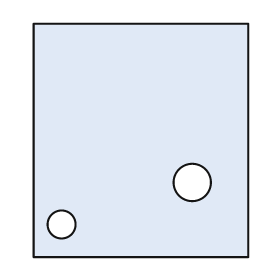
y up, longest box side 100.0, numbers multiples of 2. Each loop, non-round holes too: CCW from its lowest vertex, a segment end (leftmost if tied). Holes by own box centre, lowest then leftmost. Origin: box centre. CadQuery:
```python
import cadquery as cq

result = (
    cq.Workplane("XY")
    .moveTo(-46.0, -50.0)
    .lineTo(46.0, -50.0)
    .lineTo(46.0, 50.0)
    .lineTo(-46.0, 50.0)
    .close()
    .moveTo(-34.0, -36.0)
    .circle(6.0)
    .moveTo(22.0, -18.0)
    .circle(8.0)
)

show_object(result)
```